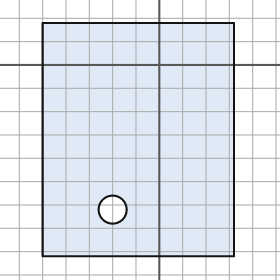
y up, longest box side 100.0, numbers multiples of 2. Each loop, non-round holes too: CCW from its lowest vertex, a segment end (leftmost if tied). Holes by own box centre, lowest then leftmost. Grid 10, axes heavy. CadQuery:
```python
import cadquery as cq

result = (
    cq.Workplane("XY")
    .moveTo(-50.0, -82.0)
    .lineTo(32.0, -82.0)
    .lineTo(32.0, 18.0)
    .lineTo(-50.0, 18.0)
    .close()
    .moveTo(-20.0, -62.0)
    .circle(6.0)
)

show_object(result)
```